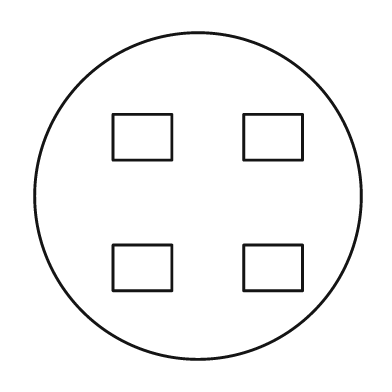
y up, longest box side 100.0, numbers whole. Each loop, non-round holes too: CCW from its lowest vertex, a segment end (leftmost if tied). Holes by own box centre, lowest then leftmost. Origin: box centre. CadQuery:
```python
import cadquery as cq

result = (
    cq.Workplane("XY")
    .moveTo(0.0, 0.0)
    .circle(50.0)
    .moveTo(-26.0, -29.0)
    .lineTo(-8.0, -29.0)
    .lineTo(-8.0, -15.0)
    .lineTo(-26.0, -15.0)
    .close()
    .moveTo(14.0, -29.0)
    .lineTo(32.0, -29.0)
    .lineTo(32.0, -15.0)
    .lineTo(14.0, -15.0)
    .close()
    .moveTo(-26.0, 11.0)
    .lineTo(-8.0, 11.0)
    .lineTo(-8.0, 25.0)
    .lineTo(-26.0, 25.0)
    .close()
    .moveTo(14.0, 11.0)
    .lineTo(32.0, 11.0)
    .lineTo(32.0, 25.0)
    .lineTo(14.0, 25.0)
    .close()
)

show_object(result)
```